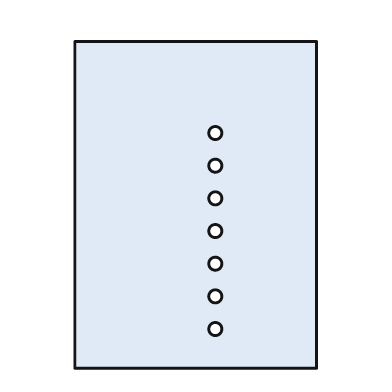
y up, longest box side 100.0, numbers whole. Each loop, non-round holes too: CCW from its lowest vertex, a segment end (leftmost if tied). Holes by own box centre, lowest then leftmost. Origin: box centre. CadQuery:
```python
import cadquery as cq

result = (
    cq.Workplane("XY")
    .moveTo(-37.0, -50.0)
    .lineTo(37.0, -50.0)
    .lineTo(37.0, 50.0)
    .lineTo(-37.0, 50.0)
    .close()
    .moveTo(6.0, -38.0)
    .circle(2.0)
    .moveTo(6.0, -28.0)
    .circle(2.0)
    .moveTo(6.0, -18.0)
    .circle(2.0)
    .moveTo(6.0, -8.0)
    .circle(2.0)
    .moveTo(6.0, 2.0)
    .circle(2.0)
    .moveTo(6.0, 12.0)
    .circle(2.0)
    .moveTo(6.0, 22.0)
    .circle(2.0)
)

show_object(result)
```